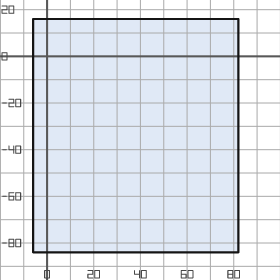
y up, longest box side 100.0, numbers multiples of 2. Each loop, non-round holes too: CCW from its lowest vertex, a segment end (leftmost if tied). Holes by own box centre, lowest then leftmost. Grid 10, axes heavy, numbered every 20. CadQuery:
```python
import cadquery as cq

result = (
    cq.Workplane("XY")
    .moveTo(-6.0, -84.0)
    .lineTo(82.0, -84.0)
    .lineTo(82.0, 16.0)
    .lineTo(-6.0, 16.0)
    .close()
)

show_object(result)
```